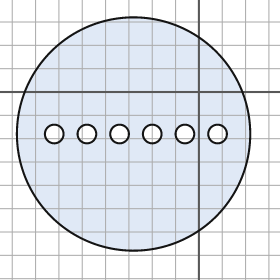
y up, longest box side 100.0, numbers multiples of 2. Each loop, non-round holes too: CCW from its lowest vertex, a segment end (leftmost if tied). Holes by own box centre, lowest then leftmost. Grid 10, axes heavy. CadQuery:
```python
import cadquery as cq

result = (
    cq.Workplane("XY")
    .moveTo(-28.0, -18.0)
    .circle(50.0)
    .moveTo(-62.0, -18.0)
    .circle(4.0)
    .moveTo(-48.0, -18.0)
    .circle(4.0)
    .moveTo(-34.0, -18.0)
    .circle(4.0)
    .moveTo(-20.0, -18.0)
    .circle(4.0)
    .moveTo(-6.0, -18.0)
    .circle(4.0)
    .moveTo(8.0, -18.0)
    .circle(4.0)
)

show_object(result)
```